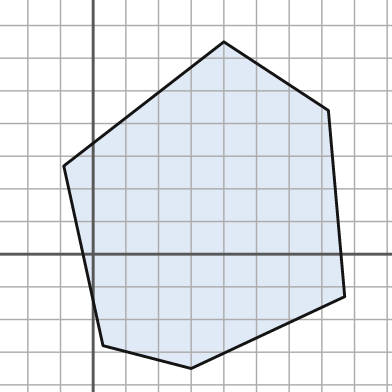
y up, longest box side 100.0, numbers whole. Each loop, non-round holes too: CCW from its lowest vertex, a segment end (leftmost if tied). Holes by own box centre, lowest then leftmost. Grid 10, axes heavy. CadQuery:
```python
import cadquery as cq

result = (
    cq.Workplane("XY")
    .moveTo(30.0, -35.0)
    .lineTo(77.0, -13.0)
    .lineTo(72.0, 44.0)
    .lineTo(40.0, 65.0)
    .lineTo(-9.0, 27.0)
    .lineTo(3.0, -28.0)
    .close()
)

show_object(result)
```